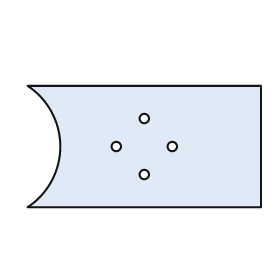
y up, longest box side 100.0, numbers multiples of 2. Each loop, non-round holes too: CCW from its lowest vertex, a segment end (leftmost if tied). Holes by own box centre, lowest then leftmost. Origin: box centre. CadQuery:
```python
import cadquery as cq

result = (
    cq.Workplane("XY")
    .moveTo(-50.0, -26.0)
    .lineTo(50.0, -26.0)
    .lineTo(50.0, 26.0)
    .lineTo(-50.0, 26.0)
    .threePointArc((-36.0, 0.0), (-50.0, -26.0))
    .close()
    .moveTo(0.0, -12.0)
    .circle(2.0)
    .moveTo(-12.0, 0.0)
    .circle(2.0)
    .moveTo(12.0, 0.0)
    .circle(2.0)
    .moveTo(0.0, 12.0)
    .circle(2.0)
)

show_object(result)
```